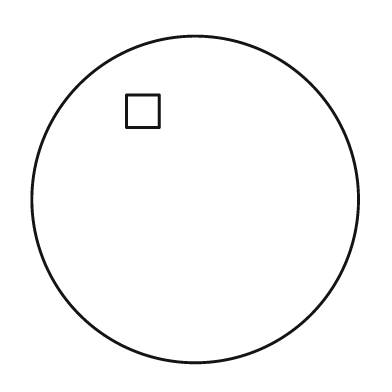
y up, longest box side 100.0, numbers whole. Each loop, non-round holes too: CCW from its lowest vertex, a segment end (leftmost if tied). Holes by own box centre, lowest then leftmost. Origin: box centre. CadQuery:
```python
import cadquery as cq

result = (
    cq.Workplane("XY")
    .moveTo(0.0, 0.0)
    .circle(50.0)
    .moveTo(-21.0, 22.0)
    .lineTo(-11.0, 22.0)
    .lineTo(-11.0, 32.0)
    .lineTo(-21.0, 32.0)
    .close()
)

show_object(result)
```